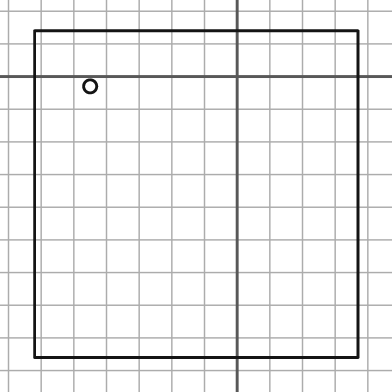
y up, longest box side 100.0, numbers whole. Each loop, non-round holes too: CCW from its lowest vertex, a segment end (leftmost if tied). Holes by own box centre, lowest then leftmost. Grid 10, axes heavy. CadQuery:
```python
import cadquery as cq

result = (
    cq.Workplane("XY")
    .moveTo(-62.0, -86.0)
    .lineTo(37.0, -86.0)
    .lineTo(37.0, 14.0)
    .lineTo(-62.0, 14.0)
    .close()
    .moveTo(-45.0, -3.0)
    .circle(2.0)
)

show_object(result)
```